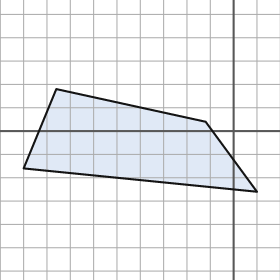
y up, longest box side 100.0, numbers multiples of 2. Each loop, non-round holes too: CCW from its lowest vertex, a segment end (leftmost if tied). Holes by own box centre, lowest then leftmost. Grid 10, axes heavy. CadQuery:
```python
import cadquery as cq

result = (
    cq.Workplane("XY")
    .moveTo(10.0, -26.0)
    .lineTo(-12.0, 4.0)
    .lineTo(-76.0, 18.0)
    .lineTo(-90.0, -16.0)
    .close()
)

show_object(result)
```